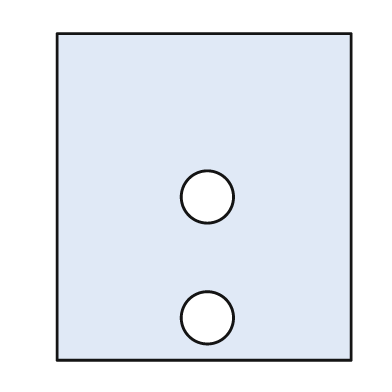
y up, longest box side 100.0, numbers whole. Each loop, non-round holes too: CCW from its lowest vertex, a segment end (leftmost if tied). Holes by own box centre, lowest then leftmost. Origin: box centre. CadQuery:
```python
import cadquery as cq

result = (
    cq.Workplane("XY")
    .moveTo(-45.0, -50.0)
    .lineTo(45.0, -50.0)
    .lineTo(45.0, 50.0)
    .lineTo(-45.0, 50.0)
    .close()
    .moveTo(1.0, -37.0)
    .circle(8.0)
    .moveTo(1.0, 0.0)
    .circle(8.0)
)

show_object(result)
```